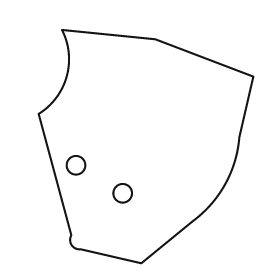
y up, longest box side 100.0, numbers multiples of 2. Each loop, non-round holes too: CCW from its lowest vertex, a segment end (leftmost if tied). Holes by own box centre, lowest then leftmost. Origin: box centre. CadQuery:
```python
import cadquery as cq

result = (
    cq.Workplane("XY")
    .moveTo(-2.0, -50.0)
    .lineTo(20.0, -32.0)
    .threePointArc((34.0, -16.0), (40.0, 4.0))
    .lineTo(46.0, 30.0)
    .lineTo(4.0, 46.0)
    .lineTo(-36.0, 50.0)
    .threePointArc((-34.0, 30.0), (-46.0, 14.0))
    .lineTo(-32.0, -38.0)
    .threePointArc((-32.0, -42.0), (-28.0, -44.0))
    .close()
    .moveTo(-10.0, -20.0)
    .circle(4.0)
    .moveTo(-30.0, -8.0)
    .circle(4.0)
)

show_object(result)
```